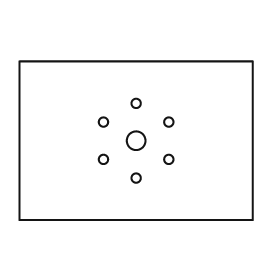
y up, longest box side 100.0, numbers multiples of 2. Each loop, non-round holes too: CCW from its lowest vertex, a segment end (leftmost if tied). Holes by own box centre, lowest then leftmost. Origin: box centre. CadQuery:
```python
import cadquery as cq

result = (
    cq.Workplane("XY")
    .moveTo(-50.0, -34.0)
    .lineTo(50.0, -34.0)
    .lineTo(50.0, 34.0)
    .lineTo(-50.0, 34.0)
    .close()
    .moveTo(0.0, -16.0)
    .circle(2.0)
    .moveTo(-14.0, -8.0)
    .circle(2.0)
    .moveTo(14.0, -8.0)
    .circle(2.0)
    .moveTo(0.0, 0.0)
    .circle(4.0)
    .moveTo(-14.0, 8.0)
    .circle(2.0)
    .moveTo(14.0, 8.0)
    .circle(2.0)
    .moveTo(0.0, 16.0)
    .circle(2.0)
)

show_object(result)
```